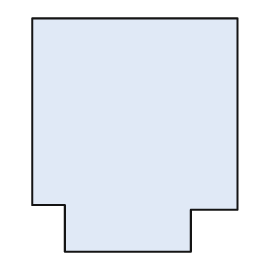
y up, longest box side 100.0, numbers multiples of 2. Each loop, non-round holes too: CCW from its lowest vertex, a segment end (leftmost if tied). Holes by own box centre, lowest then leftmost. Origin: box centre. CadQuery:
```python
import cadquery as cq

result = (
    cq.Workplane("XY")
    .moveTo(-30.0, -50.0)
    .lineTo(24.0, -50.0)
    .lineTo(24.0, -32.0)
    .lineTo(44.0, -32.0)
    .lineTo(44.0, 50.0)
    .lineTo(-44.0, 50.0)
    .lineTo(-44.0, -30.0)
    .lineTo(-30.0, -30.0)
    .close()
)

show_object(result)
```